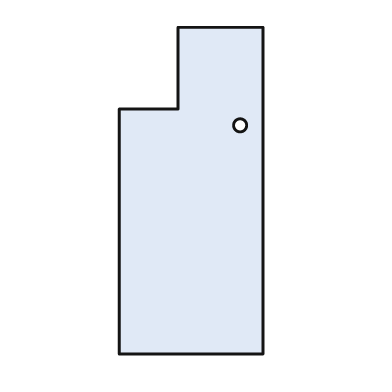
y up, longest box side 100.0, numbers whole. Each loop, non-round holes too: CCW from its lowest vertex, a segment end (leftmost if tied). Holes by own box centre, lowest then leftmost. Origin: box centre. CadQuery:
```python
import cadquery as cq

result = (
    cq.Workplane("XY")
    .moveTo(-22.0, -50.0)
    .lineTo(22.0, -50.0)
    .lineTo(22.0, 50.0)
    .lineTo(-4.0, 50.0)
    .lineTo(-4.0, 25.0)
    .lineTo(-22.0, 25.0)
    .close()
    .moveTo(15.0, 20.0)
    .circle(2.0)
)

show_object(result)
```